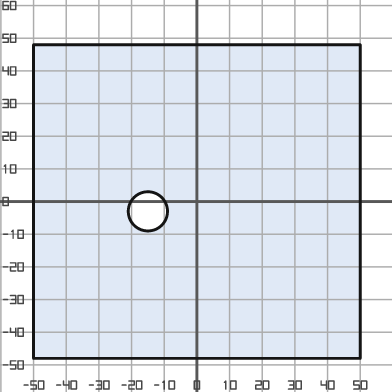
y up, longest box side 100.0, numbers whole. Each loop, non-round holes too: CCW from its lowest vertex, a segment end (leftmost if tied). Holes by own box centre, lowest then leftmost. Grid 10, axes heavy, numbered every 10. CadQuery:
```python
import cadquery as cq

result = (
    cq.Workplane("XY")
    .moveTo(-50.0, -48.0)
    .lineTo(50.0, -48.0)
    .lineTo(50.0, 48.0)
    .lineTo(-50.0, 48.0)
    .close()
    .moveTo(-15.0, -3.0)
    .circle(6.0)
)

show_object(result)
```